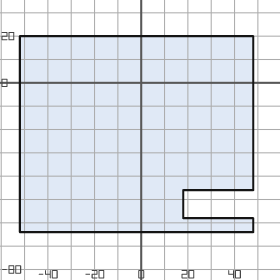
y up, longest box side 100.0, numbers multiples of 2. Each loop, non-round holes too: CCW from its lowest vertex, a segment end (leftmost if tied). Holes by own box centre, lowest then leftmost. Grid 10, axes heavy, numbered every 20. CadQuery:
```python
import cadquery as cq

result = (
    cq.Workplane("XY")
    .moveTo(-52.0, -64.0)
    .lineTo(48.0, -64.0)
    .lineTo(48.0, -58.0)
    .lineTo(18.0, -58.0)
    .lineTo(18.0, -46.0)
    .lineTo(48.0, -46.0)
    .lineTo(48.0, 20.0)
    .lineTo(-52.0, 20.0)
    .close()
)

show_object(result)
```